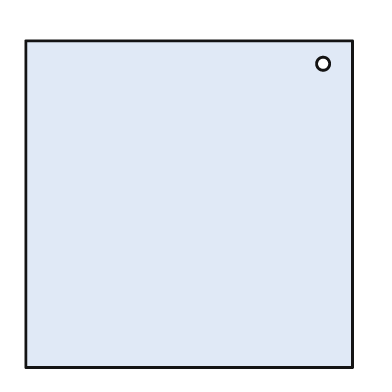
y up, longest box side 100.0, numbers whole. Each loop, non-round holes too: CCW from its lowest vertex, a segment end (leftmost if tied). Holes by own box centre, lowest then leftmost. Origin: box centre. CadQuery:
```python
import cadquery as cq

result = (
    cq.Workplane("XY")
    .moveTo(-50.0, -50.0)
    .lineTo(50.0, -50.0)
    .lineTo(50.0, 50.0)
    .lineTo(-50.0, 50.0)
    .close()
    .moveTo(41.0, 43.0)
    .circle(2.0)
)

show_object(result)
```